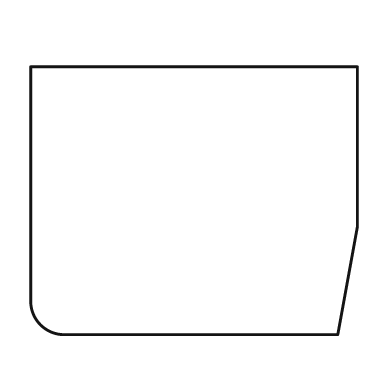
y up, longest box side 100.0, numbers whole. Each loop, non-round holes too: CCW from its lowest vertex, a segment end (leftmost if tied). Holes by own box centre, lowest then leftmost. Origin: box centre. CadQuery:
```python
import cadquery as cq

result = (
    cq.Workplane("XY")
    .moveTo(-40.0, -41.0)
    .lineTo(44.0, -41.0)
    .lineTo(50.0, -8.0)
    .lineTo(50.0, 41.0)
    .lineTo(-50.0, 41.0)
    .lineTo(-50.0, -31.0)
    .threePointArc((-47.0, -38.0), (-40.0, -41.0))
    .close()
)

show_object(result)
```